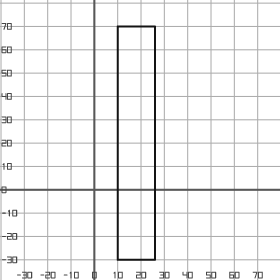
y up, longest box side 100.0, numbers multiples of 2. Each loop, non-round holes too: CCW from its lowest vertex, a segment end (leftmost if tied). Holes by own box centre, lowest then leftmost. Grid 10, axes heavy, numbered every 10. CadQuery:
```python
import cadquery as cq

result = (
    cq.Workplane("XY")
    .moveTo(10.0, -30.0)
    .lineTo(26.0, -30.0)
    .lineTo(26.0, 70.0)
    .lineTo(10.0, 70.0)
    .close()
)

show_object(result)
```